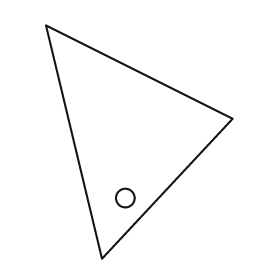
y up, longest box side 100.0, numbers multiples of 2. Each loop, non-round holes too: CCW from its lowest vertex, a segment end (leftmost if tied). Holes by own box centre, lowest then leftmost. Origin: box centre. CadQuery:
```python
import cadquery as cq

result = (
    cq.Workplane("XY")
    .moveTo(-16.0, -50.0)
    .lineTo(40.0, 10.0)
    .lineTo(-40.0, 50.0)
    .close()
    .moveTo(-6.0, -24.0)
    .circle(4.0)
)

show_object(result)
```